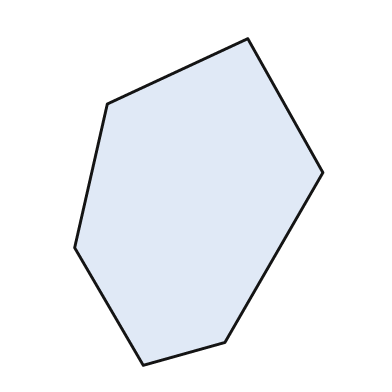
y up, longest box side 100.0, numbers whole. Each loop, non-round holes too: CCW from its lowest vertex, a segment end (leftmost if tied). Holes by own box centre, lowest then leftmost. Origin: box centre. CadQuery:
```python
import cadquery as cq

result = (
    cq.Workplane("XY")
    .moveTo(-17.0, -50.0)
    .lineTo(8.0, -43.0)
    .lineTo(38.0, 9.0)
    .lineTo(15.0, 50.0)
    .lineTo(-28.0, 30.0)
    .lineTo(-38.0, -14.0)
    .close()
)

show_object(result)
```